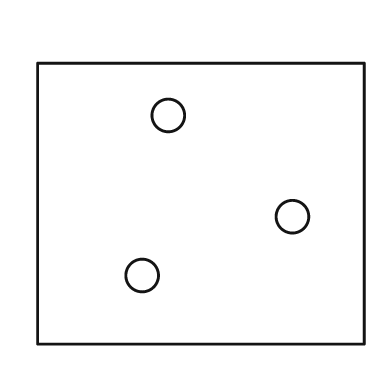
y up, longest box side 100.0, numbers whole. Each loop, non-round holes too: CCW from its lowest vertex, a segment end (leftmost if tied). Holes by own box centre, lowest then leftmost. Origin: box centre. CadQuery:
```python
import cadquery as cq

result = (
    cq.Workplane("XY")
    .moveTo(-50.0, -43.0)
    .lineTo(50.0, -43.0)
    .lineTo(50.0, 43.0)
    .lineTo(-50.0, 43.0)
    .close()
    .moveTo(-18.0, -22.0)
    .circle(5.0)
    .moveTo(28.0, -4.0)
    .circle(5.0)
    .moveTo(-10.0, 27.0)
    .circle(5.0)
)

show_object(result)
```